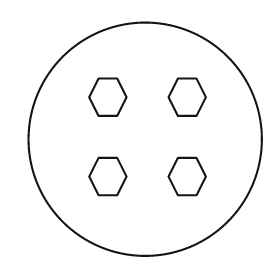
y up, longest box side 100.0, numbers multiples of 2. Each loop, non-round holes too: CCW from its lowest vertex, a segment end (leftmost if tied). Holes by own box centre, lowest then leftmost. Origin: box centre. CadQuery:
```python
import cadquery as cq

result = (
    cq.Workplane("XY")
    .moveTo(0.0, 0.0)
    .circle(50.0)
    .moveTo(-20.0, -24.0)
    .lineTo(-12.0, -24.0)
    .lineTo(-8.0, -16.0)
    .lineTo(-12.0, -8.0)
    .lineTo(-20.0, -8.0)
    .lineTo(-24.0, -16.0)
    .close()
    .moveTo(14.0, -24.0)
    .lineTo(22.0, -24.0)
    .lineTo(26.0, -16.0)
    .lineTo(22.0, -8.0)
    .lineTo(14.0, -8.0)
    .lineTo(10.0, -16.0)
    .close()
    .moveTo(-20.0, 10.0)
    .lineTo(-12.0, 10.0)
    .lineTo(-8.0, 18.0)
    .lineTo(-12.0, 26.0)
    .lineTo(-20.0, 26.0)
    .lineTo(-24.0, 18.0)
    .close()
    .moveTo(14.0, 10.0)
    .lineTo(22.0, 10.0)
    .lineTo(26.0, 18.0)
    .lineTo(22.0, 26.0)
    .lineTo(14.0, 26.0)
    .lineTo(10.0, 18.0)
    .close()
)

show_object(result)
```